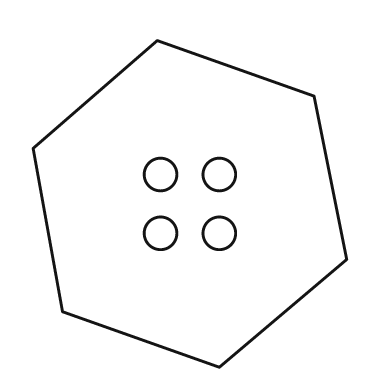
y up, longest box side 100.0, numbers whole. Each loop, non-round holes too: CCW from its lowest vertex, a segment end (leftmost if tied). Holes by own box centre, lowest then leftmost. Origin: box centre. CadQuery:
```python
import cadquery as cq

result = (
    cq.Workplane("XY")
    .moveTo(9.0, -50.0)
    .lineTo(48.0, -17.0)
    .lineTo(38.0, 33.0)
    .lineTo(-10.0, 50.0)
    .lineTo(-48.0, 17.0)
    .lineTo(-39.0, -33.0)
    .close()
    .moveTo(-9.0, -9.0)
    .circle(5.0)
    .moveTo(9.0, -9.0)
    .circle(5.0)
    .moveTo(-9.0, 9.0)
    .circle(5.0)
    .moveTo(9.0, 9.0)
    .circle(5.0)
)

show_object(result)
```